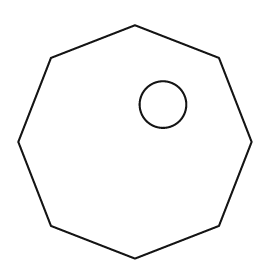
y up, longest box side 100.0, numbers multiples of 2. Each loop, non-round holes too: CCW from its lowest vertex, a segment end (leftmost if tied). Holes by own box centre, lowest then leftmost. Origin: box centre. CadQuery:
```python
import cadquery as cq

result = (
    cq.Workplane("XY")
    .moveTo(0.0, -50.0)
    .lineTo(36.0, -36.0)
    .lineTo(50.0, 0.0)
    .lineTo(36.0, 36.0)
    .lineTo(0.0, 50.0)
    .lineTo(-36.0, 36.0)
    .lineTo(-50.0, 0.0)
    .lineTo(-36.0, -36.0)
    .close()
    .moveTo(12.0, 16.0)
    .circle(10.0)
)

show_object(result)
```